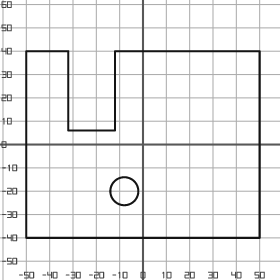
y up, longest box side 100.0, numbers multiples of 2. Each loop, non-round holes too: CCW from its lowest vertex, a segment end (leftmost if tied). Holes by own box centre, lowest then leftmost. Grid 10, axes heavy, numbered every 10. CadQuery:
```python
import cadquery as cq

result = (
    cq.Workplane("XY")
    .moveTo(-50.0, -40.0)
    .lineTo(50.0, -40.0)
    .lineTo(50.0, 40.0)
    .lineTo(-12.0, 40.0)
    .lineTo(-12.0, 6.0)
    .lineTo(-32.0, 6.0)
    .lineTo(-32.0, 40.0)
    .lineTo(-50.0, 40.0)
    .close()
    .moveTo(-8.0, -20.0)
    .circle(6.0)
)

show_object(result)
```